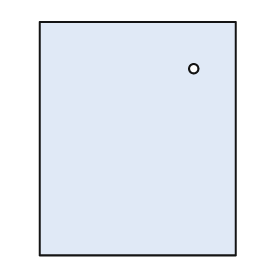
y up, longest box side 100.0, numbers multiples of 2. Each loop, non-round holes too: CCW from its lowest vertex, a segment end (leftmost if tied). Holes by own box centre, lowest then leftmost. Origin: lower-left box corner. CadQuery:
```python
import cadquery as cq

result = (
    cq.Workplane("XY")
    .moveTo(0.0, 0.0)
    .lineTo(84.0, 0.0)
    .lineTo(84.0, 100.0)
    .lineTo(0.0, 100.0)
    .close()
    .moveTo(66.0, 80.0)
    .circle(2.0)
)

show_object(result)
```